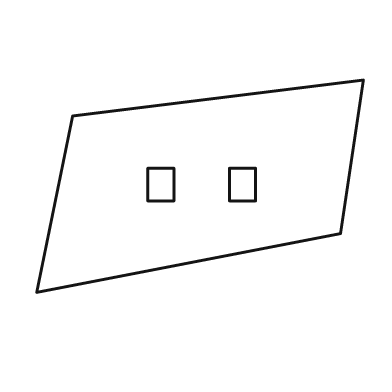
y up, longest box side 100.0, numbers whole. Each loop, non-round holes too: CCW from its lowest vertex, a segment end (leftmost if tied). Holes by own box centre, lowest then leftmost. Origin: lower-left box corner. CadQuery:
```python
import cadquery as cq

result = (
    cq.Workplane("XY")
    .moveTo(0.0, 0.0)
    .lineTo(93.0, 18.0)
    .lineTo(100.0, 65.0)
    .lineTo(11.0, 54.0)
    .close()
    .moveTo(34.0, 28.0)
    .lineTo(42.0, 28.0)
    .lineTo(42.0, 38.0)
    .lineTo(34.0, 38.0)
    .close()
    .moveTo(59.0, 28.0)
    .lineTo(67.0, 28.0)
    .lineTo(67.0, 38.0)
    .lineTo(59.0, 38.0)
    .close()
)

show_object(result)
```